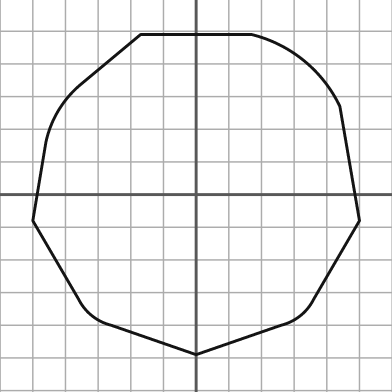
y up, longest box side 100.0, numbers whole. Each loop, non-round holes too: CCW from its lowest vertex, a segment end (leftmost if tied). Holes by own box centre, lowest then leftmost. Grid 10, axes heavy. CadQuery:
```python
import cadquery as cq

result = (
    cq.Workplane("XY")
    .moveTo(0.0, -49.0)
    .lineTo(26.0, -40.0)
    .threePointArc((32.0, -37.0), (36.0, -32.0))
    .lineTo(50.0, -8.0)
    .lineTo(44.0, 27.0)
    .threePointArc((33.0, 41.0), (17.0, 49.0))
    .lineTo(-17.0, 49.0)
    .lineTo(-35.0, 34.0)
    .threePointArc((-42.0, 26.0), (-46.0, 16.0))
    .lineTo(-50.0, -8.0)
    .lineTo(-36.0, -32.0)
    .threePointArc((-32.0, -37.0), (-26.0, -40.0))
    .close()
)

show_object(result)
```